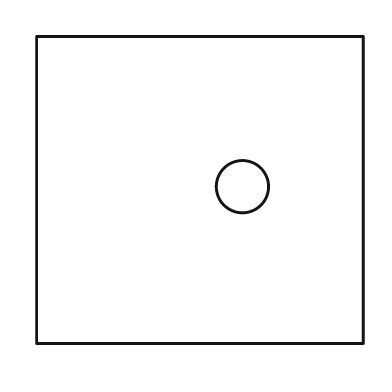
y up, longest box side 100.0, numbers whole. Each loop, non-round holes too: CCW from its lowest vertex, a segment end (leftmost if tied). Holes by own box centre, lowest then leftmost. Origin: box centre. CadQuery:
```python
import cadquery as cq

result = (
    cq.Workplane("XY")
    .moveTo(-50.0, -47.0)
    .lineTo(50.0, -47.0)
    .lineTo(50.0, 47.0)
    .lineTo(-50.0, 47.0)
    .close()
    .moveTo(13.0, 1.0)
    .circle(8.0)
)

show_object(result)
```